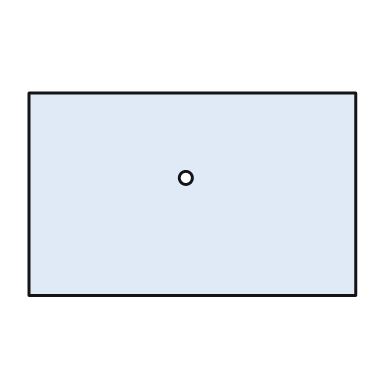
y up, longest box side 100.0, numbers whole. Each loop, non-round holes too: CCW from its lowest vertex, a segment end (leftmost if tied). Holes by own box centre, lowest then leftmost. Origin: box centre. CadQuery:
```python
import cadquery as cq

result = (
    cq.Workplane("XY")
    .moveTo(-50.0, -31.0)
    .lineTo(50.0, -31.0)
    .lineTo(50.0, 31.0)
    .lineTo(-50.0, 31.0)
    .close()
    .moveTo(-2.0, 5.0)
    .circle(2.0)
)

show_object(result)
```